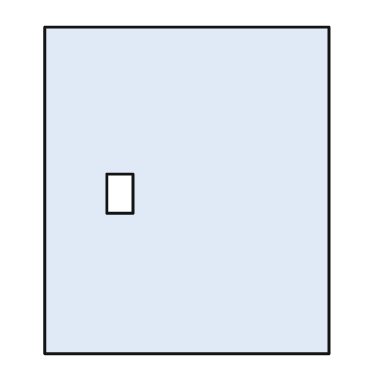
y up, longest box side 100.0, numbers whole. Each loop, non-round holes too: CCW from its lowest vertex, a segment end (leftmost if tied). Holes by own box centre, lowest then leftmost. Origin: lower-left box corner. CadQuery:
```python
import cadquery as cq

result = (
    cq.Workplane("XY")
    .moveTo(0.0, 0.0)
    .lineTo(87.0, 0.0)
    .lineTo(87.0, 100.0)
    .lineTo(0.0, 100.0)
    .close()
    .moveTo(19.0, 43.0)
    .lineTo(27.0, 43.0)
    .lineTo(27.0, 55.0)
    .lineTo(19.0, 55.0)
    .close()
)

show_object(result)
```